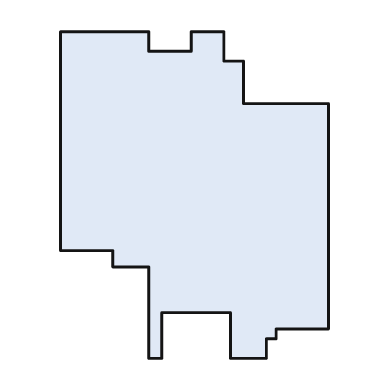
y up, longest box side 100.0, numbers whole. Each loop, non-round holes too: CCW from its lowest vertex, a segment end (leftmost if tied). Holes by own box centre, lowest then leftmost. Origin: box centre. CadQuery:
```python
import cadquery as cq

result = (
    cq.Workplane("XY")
    .moveTo(-14.0, -50.0)
    .lineTo(-10.0, -50.0)
    .lineTo(-10.0, -36.0)
    .lineTo(11.0, -36.0)
    .lineTo(11.0, -50.0)
    .lineTo(22.0, -50.0)
    .lineTo(22.0, -44.0)
    .lineTo(25.0, -44.0)
    .lineTo(25.0, -41.0)
    .lineTo(41.0, -41.0)
    .lineTo(41.0, 28.0)
    .lineTo(15.0, 28.0)
    .lineTo(15.0, 41.0)
    .lineTo(9.0, 41.0)
    .lineTo(9.0, 50.0)
    .lineTo(-1.0, 50.0)
    .lineTo(-1.0, 44.0)
    .lineTo(-14.0, 44.0)
    .lineTo(-14.0, 50.0)
    .lineTo(-41.0, 50.0)
    .lineTo(-41.0, -17.0)
    .lineTo(-25.0, -17.0)
    .lineTo(-25.0, -22.0)
    .lineTo(-14.0, -22.0)
    .close()
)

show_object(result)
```